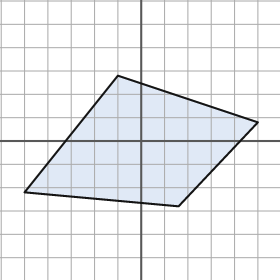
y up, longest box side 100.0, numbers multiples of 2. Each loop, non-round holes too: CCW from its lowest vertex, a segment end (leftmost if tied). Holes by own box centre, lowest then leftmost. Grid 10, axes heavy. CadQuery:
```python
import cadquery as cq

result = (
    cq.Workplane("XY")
    .moveTo(16.0, -28.0)
    .lineTo(50.0, 8.0)
    .lineTo(-10.0, 28.0)
    .lineTo(-50.0, -22.0)
    .close()
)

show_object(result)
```